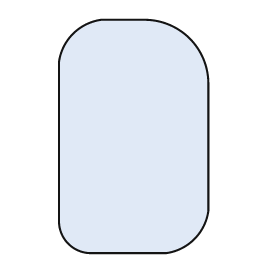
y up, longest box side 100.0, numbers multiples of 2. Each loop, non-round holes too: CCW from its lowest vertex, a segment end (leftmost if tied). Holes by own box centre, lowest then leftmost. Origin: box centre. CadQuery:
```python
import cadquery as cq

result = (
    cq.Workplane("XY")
    .moveTo(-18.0, -50.0)
    .lineTo(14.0, -50.0)
    .threePointArc((26.0, -44.0), (32.0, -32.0))
    .lineTo(32.0, 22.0)
    .threePointArc((24.0, 42.0), (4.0, 50.0))
    .lineTo(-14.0, 50.0)
    .threePointArc((-26.0, 44.0), (-32.0, 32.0))
    .lineTo(-32.0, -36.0)
    .threePointArc((-28.0, -46.0), (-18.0, -50.0))
    .close()
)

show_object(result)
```